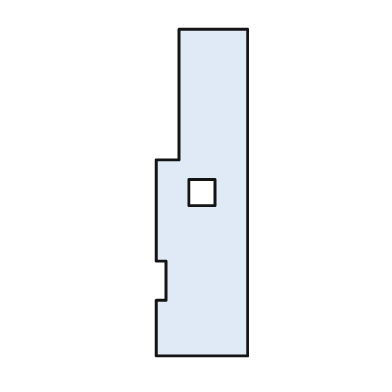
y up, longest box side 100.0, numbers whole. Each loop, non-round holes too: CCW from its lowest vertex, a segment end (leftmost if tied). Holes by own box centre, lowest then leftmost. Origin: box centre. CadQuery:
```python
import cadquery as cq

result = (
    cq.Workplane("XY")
    .moveTo(-14.0, -50.0)
    .lineTo(14.0, -50.0)
    .lineTo(14.0, 50.0)
    .lineTo(-7.0, 50.0)
    .lineTo(-7.0, 10.0)
    .lineTo(-14.0, 10.0)
    .lineTo(-14.0, -21.0)
    .lineTo(-11.0, -21.0)
    .lineTo(-11.0, -33.0)
    .lineTo(-14.0, -33.0)
    .close()
    .moveTo(-4.0, -4.0)
    .lineTo(4.0, -4.0)
    .lineTo(4.0, 4.0)
    .lineTo(-4.0, 4.0)
    .close()
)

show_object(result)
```